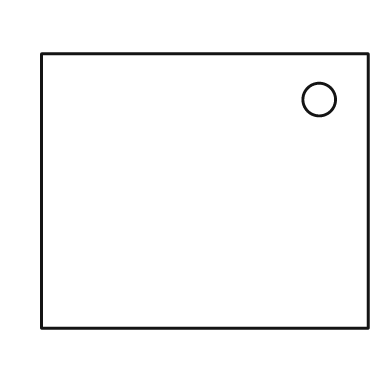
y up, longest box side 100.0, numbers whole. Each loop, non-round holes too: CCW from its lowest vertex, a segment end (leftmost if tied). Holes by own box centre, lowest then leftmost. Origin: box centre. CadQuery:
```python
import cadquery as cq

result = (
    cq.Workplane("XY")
    .moveTo(-50.0, -42.0)
    .lineTo(50.0, -42.0)
    .lineTo(50.0, 42.0)
    .lineTo(-50.0, 42.0)
    .close()
    .moveTo(35.0, 28.0)
    .circle(5.0)
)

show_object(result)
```